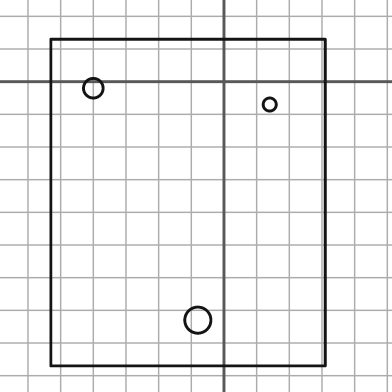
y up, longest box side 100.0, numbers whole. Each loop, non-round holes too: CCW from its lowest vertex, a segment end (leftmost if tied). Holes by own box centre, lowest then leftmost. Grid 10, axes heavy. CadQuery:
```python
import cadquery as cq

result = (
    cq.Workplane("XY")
    .moveTo(-53.0, -87.0)
    .lineTo(31.0, -87.0)
    .lineTo(31.0, 13.0)
    .lineTo(-53.0, 13.0)
    .close()
    .moveTo(-8.0, -73.0)
    .circle(4.0)
    .moveTo(14.0, -7.0)
    .circle(2.0)
    .moveTo(-40.0, -2.0)
    .circle(3.0)
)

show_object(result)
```